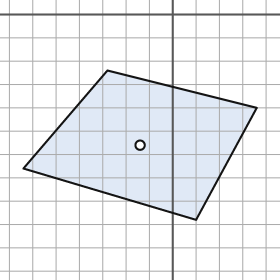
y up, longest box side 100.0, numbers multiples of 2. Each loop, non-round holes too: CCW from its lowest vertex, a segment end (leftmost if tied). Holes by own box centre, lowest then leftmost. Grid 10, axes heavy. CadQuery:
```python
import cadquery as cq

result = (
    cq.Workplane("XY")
    .moveTo(10.0, -88.0)
    .lineTo(36.0, -40.0)
    .lineTo(-28.0, -24.0)
    .lineTo(-64.0, -66.0)
    .close()
    .moveTo(-14.0, -56.0)
    .circle(2.0)
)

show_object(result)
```